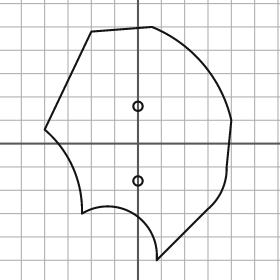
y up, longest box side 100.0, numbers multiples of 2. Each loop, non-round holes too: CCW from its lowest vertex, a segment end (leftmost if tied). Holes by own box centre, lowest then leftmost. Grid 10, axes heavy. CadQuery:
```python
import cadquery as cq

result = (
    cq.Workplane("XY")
    .moveTo(8.0, -50.0)
    .lineTo(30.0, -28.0)
    .threePointArc((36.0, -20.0), (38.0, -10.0))
    .lineTo(40.0, 10.0)
    .threePointArc((28.0, 34.0), (6.0, 50.0))
    .lineTo(-20.0, 48.0)
    .lineTo(-40.0, 6.0)
    .threePointArc((-28.0, -10.0), (-24.0, -30.0))
    .threePointArc((-2.0, -30.0), (8.0, -50.0))
    .close()
    .moveTo(0.0, -16.0)
    .circle(2.0)
    .moveTo(0.0, 16.0)
    .circle(2.0)
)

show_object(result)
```